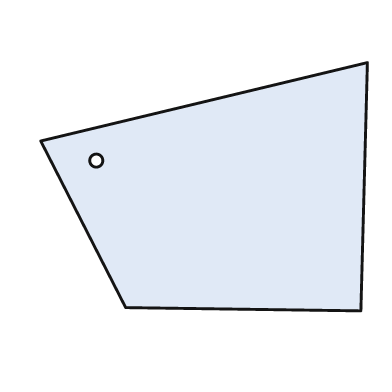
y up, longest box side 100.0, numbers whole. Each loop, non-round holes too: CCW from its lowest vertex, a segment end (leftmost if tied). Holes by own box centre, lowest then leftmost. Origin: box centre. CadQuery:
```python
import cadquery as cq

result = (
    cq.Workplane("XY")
    .moveTo(48.0, -38.0)
    .lineTo(50.0, 38.0)
    .lineTo(-50.0, 14.0)
    .lineTo(-24.0, -37.0)
    .close()
    .moveTo(-33.0, 8.0)
    .circle(2.0)
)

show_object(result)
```